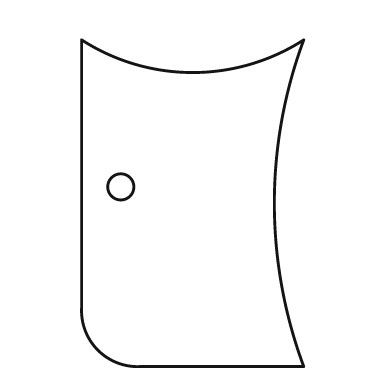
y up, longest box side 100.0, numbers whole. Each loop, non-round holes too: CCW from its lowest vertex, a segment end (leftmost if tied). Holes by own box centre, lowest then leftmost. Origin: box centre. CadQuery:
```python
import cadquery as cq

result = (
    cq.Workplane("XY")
    .moveTo(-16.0, -50.0)
    .lineTo(34.0, -50.0)
    .threePointArc((25.0, 0.0), (34.0, 50.0))
    .threePointArc((0.0, 40.0), (-34.0, 50.0))
    .lineTo(-34.0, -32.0)
    .threePointArc((-29.0, -45.0), (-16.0, -50.0))
    .close()
    .moveTo(-22.0, 5.0)
    .circle(4.0)
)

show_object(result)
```